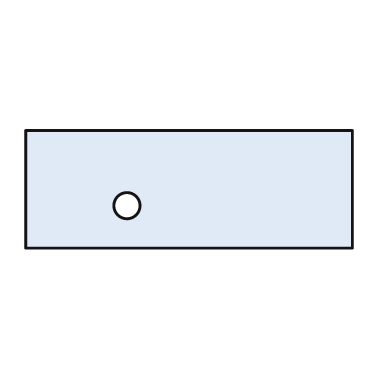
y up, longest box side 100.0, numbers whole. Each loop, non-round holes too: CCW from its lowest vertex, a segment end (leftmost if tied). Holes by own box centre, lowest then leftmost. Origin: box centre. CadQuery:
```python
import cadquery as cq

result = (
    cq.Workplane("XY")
    .moveTo(-50.0, -18.0)
    .lineTo(50.0, -18.0)
    .lineTo(50.0, 18.0)
    .lineTo(-50.0, 18.0)
    .close()
    .moveTo(-19.0, -5.0)
    .circle(4.0)
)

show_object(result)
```